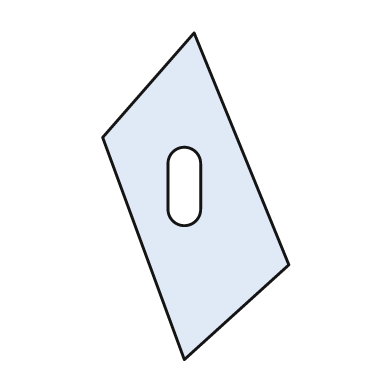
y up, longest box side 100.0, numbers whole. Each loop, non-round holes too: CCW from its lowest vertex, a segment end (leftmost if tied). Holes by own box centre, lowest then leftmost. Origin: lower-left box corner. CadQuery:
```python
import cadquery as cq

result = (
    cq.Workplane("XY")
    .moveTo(25.0, 0.0)
    .lineTo(57.0, 29.0)
    .lineTo(28.0, 100.0)
    .lineTo(0.0, 68.0)
    .close()
    .moveTo(20.0, 46.0)
    .threePointArc((25.0, 41.0), (30.0, 46.0))
    .lineTo(30.0, 60.0)
    .threePointArc((25.0, 65.0), (20.0, 60.0))
    .close()
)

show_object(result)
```